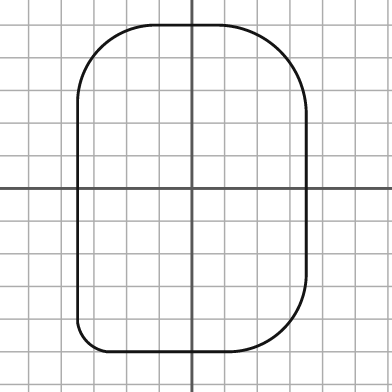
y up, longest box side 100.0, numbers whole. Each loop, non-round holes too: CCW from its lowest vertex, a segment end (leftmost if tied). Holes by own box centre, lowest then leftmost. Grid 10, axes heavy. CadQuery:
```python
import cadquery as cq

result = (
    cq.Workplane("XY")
    .moveTo(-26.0, -50.0)
    .lineTo(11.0, -50.0)
    .threePointArc((28.0, -43.0), (35.0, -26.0))
    .lineTo(35.0, 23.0)
    .threePointArc((27.0, 42.0), (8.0, 50.0))
    .lineTo(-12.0, 50.0)
    .threePointArc((-28.0, 43.0), (-35.0, 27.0))
    .lineTo(-35.0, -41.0)
    .threePointArc((-32.0, -47.0), (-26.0, -50.0))
    .close()
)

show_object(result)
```